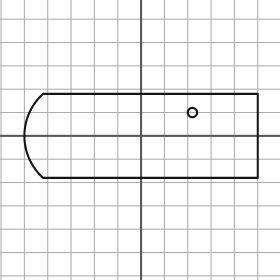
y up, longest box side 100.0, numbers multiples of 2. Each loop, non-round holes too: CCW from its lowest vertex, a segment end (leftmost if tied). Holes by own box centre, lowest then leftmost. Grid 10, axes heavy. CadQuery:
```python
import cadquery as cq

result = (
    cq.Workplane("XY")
    .moveTo(-42.0, -18.0)
    .lineTo(50.0, -18.0)
    .lineTo(50.0, 18.0)
    .lineTo(-42.0, 18.0)
    .threePointArc((-50.0, 0.0), (-42.0, -18.0))
    .close()
    .moveTo(22.0, 10.0)
    .circle(2.0)
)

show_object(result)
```